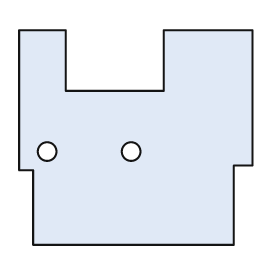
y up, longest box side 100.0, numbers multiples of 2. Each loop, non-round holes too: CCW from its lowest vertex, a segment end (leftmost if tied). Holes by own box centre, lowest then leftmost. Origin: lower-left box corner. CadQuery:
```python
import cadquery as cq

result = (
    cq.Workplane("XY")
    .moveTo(6.0, 0.0)
    .lineTo(92.0, 0.0)
    .lineTo(92.0, 34.0)
    .lineTo(100.0, 34.0)
    .lineTo(100.0, 92.0)
    .lineTo(62.0, 92.0)
    .lineTo(62.0, 66.0)
    .lineTo(20.0, 66.0)
    .lineTo(20.0, 92.0)
    .lineTo(0.0, 92.0)
    .lineTo(0.0, 32.0)
    .lineTo(6.0, 32.0)
    .close()
    .moveTo(12.0, 40.0)
    .circle(4.0)
    .moveTo(48.0, 40.0)
    .circle(4.0)
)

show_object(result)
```